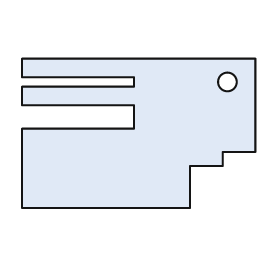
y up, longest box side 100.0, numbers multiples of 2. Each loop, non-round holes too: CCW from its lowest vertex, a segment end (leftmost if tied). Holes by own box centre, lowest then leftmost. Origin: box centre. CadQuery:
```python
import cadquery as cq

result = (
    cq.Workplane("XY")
    .moveTo(-50.0, -32.0)
    .lineTo(22.0, -32.0)
    .lineTo(22.0, -14.0)
    .lineTo(36.0, -14.0)
    .lineTo(36.0, -8.0)
    .lineTo(50.0, -8.0)
    .lineTo(50.0, 32.0)
    .lineTo(-50.0, 32.0)
    .lineTo(-50.0, 24.0)
    .lineTo(-2.0, 24.0)
    .lineTo(-2.0, 20.0)
    .lineTo(-50.0, 20.0)
    .lineTo(-50.0, 12.0)
    .lineTo(-2.0, 12.0)
    .lineTo(-2.0, 2.0)
    .lineTo(-50.0, 2.0)
    .close()
    .moveTo(38.0, 22.0)
    .circle(4.0)
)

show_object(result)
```